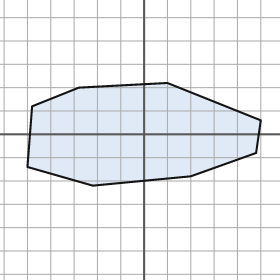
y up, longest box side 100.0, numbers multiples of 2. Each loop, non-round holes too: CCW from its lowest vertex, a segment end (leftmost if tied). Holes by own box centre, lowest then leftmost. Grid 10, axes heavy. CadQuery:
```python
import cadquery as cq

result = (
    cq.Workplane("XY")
    .moveTo(-22.0, -22.0)
    .lineTo(20.0, -18.0)
    .lineTo(48.0, -8.0)
    .lineTo(50.0, 6.0)
    .lineTo(10.0, 22.0)
    .lineTo(-28.0, 20.0)
    .lineTo(-48.0, 12.0)
    .lineTo(-50.0, -14.0)
    .close()
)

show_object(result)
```